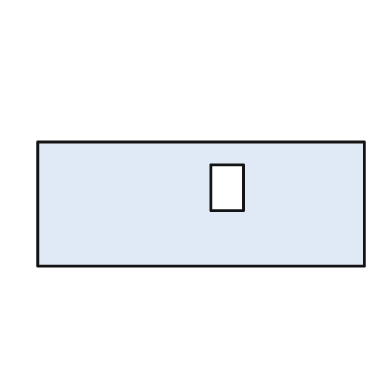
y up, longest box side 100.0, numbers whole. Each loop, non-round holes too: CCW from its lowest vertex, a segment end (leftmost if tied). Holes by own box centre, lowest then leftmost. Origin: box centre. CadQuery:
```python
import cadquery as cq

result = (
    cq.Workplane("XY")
    .moveTo(-50.0, -19.0)
    .lineTo(50.0, -19.0)
    .lineTo(50.0, 19.0)
    .lineTo(-50.0, 19.0)
    .close()
    .moveTo(3.0, -2.0)
    .lineTo(13.0, -2.0)
    .lineTo(13.0, 12.0)
    .lineTo(3.0, 12.0)
    .close()
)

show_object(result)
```